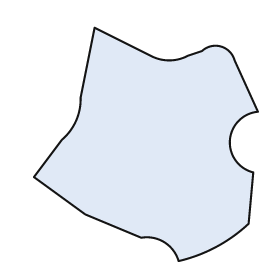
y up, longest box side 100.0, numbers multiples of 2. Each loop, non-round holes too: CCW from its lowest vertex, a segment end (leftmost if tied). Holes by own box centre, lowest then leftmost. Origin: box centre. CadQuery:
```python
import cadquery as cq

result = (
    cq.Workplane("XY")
    .moveTo(14.0, -50.0)
    .threePointArc((30.0, -44.0), (44.0, -34.0))
    .lineTo(46.0, -12.0)
    .threePointArc((36.0, 2.0), (48.0, 14.0))
    .lineTo(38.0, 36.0)
    .threePointArc((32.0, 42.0), (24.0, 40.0))
    .lineTo(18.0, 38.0)
    .threePointArc((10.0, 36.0), (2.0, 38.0))
    .lineTo(-22.0, 50.0)
    .lineTo(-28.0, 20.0)
    .threePointArc((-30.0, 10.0), (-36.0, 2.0))
    .lineTo(-48.0, -14.0)
    .lineTo(-26.0, -30.0)
    .lineTo(-2.0, -40.0)
    .threePointArc((8.0, -42.0), (14.0, -50.0))
    .close()
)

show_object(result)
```